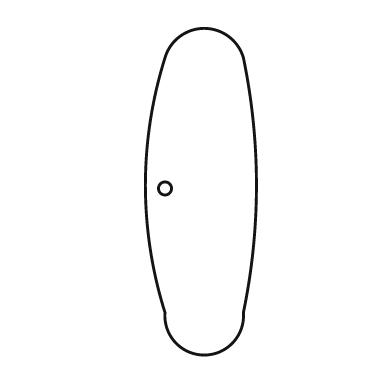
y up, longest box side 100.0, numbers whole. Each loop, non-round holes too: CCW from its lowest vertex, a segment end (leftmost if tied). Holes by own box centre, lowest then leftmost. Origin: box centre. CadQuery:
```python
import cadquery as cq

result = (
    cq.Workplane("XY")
    .moveTo(-11.0, -37.0)
    .threePointArc((1.0, -50.0), (13.0, -37.0))
    .threePointArc((17.0, 2.0), (13.0, 41.0))
    .threePointArc((1.0, 50.0), (-11.0, 41.0))
    .threePointArc((-17.0, 2.0), (-11.0, -37.0))
    .close()
    .moveTo(-11.0, 1.0)
    .circle(2.0)
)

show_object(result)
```